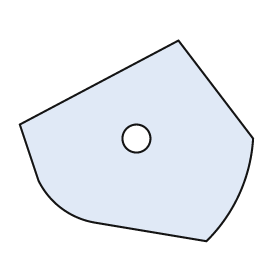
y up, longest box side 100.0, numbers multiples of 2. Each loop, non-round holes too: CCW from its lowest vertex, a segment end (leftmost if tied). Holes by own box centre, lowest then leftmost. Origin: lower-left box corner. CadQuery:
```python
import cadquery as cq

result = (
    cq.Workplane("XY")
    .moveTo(80.0, 0.0)
    .threePointArc((94.0, 20.0), (100.0, 44.0))
    .lineTo(68.0, 86.0)
    .lineTo(0.0, 50.0)
    .lineTo(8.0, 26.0)
    .threePointArc((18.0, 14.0), (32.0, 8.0))
    .close()
    .moveTo(50.0, 44.0)
    .circle(6.0)
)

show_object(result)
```